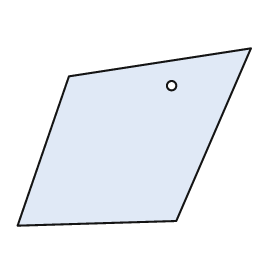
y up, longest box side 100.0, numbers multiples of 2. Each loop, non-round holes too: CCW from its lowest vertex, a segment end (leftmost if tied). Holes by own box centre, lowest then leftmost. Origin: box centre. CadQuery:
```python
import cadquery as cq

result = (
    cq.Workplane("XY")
    .moveTo(-50.0, -38.0)
    .lineTo(18.0, -36.0)
    .lineTo(50.0, 38.0)
    .lineTo(-28.0, 26.0)
    .close()
    .moveTo(16.0, 22.0)
    .circle(2.0)
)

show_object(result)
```